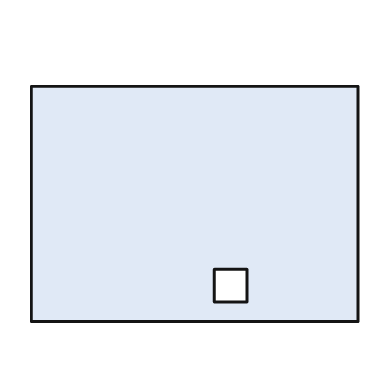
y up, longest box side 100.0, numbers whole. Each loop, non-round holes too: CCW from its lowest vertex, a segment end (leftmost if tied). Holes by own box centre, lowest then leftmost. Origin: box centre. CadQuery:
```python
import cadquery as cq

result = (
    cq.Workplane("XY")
    .moveTo(-50.0, -36.0)
    .lineTo(50.0, -36.0)
    .lineTo(50.0, 36.0)
    .lineTo(-50.0, 36.0)
    .close()
    .moveTo(6.0, -30.0)
    .lineTo(16.0, -30.0)
    .lineTo(16.0, -20.0)
    .lineTo(6.0, -20.0)
    .close()
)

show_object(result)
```